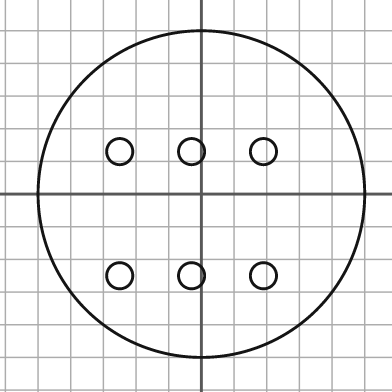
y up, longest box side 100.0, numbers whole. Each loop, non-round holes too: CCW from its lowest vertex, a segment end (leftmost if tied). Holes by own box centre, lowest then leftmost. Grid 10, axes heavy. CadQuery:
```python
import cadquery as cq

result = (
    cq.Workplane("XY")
    .moveTo(0.0, 0.0)
    .circle(50.0)
    .moveTo(-25.0, -25.0)
    .circle(4.0)
    .moveTo(-3.0, -25.0)
    .circle(4.0)
    .moveTo(19.0, -25.0)
    .circle(4.0)
    .moveTo(-25.0, 13.0)
    .circle(4.0)
    .moveTo(-3.0, 13.0)
    .circle(4.0)
    .moveTo(19.0, 13.0)
    .circle(4.0)
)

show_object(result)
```